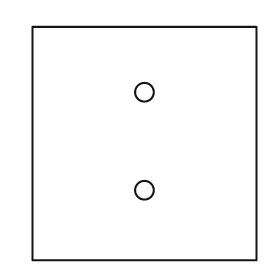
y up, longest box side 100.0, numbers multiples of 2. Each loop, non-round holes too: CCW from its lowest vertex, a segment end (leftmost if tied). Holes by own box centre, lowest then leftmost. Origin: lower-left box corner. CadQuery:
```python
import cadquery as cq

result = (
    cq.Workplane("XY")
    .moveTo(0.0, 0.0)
    .lineTo(96.0, 0.0)
    .lineTo(96.0, 100.0)
    .lineTo(0.0, 100.0)
    .close()
    .moveTo(48.0, 30.0)
    .circle(4.0)
    .moveTo(48.0, 72.0)
    .circle(4.0)
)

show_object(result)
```